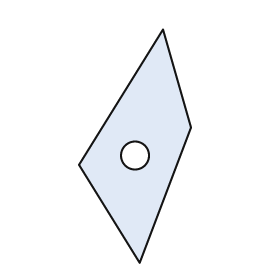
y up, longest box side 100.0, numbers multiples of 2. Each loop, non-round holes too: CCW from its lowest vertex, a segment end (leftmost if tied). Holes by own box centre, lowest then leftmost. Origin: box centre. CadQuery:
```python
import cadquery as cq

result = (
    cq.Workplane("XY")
    .moveTo(2.0, -50.0)
    .lineTo(24.0, 8.0)
    .lineTo(12.0, 50.0)
    .lineTo(-24.0, -8.0)
    .close()
    .moveTo(0.0, -4.0)
    .circle(6.0)
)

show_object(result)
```